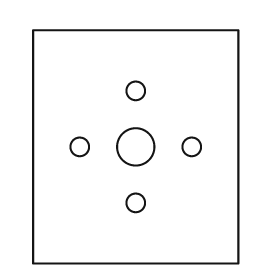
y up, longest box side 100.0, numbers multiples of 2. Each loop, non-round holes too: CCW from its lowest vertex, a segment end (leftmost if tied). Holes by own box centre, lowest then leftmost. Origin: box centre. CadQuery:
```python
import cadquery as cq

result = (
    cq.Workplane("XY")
    .moveTo(-44.0, -50.0)
    .lineTo(44.0, -50.0)
    .lineTo(44.0, 50.0)
    .lineTo(-44.0, 50.0)
    .close()
    .moveTo(0.0, -24.0)
    .circle(4.0)
    .moveTo(-24.0, 0.0)
    .circle(4.0)
    .moveTo(0.0, 0.0)
    .circle(8.0)
    .moveTo(24.0, 0.0)
    .circle(4.0)
    .moveTo(0.0, 24.0)
    .circle(4.0)
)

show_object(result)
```